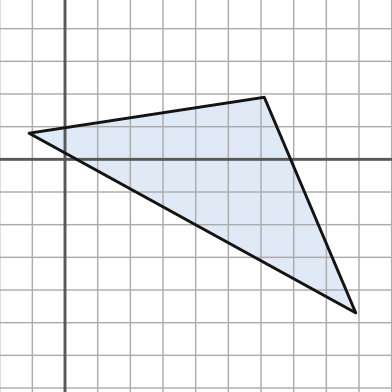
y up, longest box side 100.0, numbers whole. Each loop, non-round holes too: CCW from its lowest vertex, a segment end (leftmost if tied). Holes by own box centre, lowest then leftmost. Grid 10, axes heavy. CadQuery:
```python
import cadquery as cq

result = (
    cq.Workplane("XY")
    .moveTo(89.0, -47.0)
    .lineTo(61.0, 19.0)
    .lineTo(-11.0, 8.0)
    .close()
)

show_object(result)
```